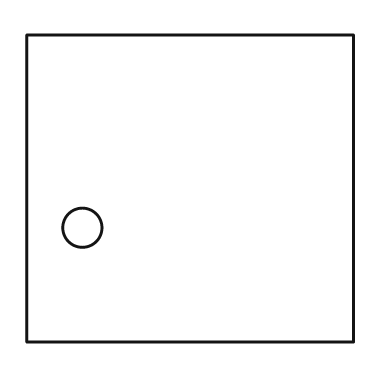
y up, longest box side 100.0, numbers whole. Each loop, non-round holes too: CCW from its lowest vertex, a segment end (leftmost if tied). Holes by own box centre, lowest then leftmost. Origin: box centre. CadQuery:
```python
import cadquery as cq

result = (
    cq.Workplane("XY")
    .moveTo(-50.0, -47.0)
    .lineTo(50.0, -47.0)
    .lineTo(50.0, 47.0)
    .lineTo(-50.0, 47.0)
    .close()
    .moveTo(-33.0, -12.0)
    .circle(6.0)
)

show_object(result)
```